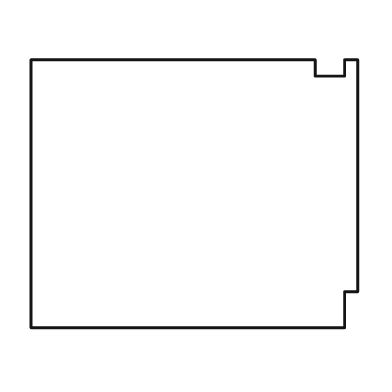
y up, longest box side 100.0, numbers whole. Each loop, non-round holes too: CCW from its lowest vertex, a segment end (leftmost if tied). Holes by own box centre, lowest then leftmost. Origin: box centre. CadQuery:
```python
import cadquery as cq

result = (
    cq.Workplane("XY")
    .moveTo(-50.0, -41.0)
    .lineTo(46.0, -41.0)
    .lineTo(46.0, -30.0)
    .lineTo(50.0, -30.0)
    .lineTo(50.0, 41.0)
    .lineTo(46.0, 41.0)
    .lineTo(46.0, 36.0)
    .lineTo(37.0, 36.0)
    .lineTo(37.0, 41.0)
    .lineTo(-50.0, 41.0)
    .close()
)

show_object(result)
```